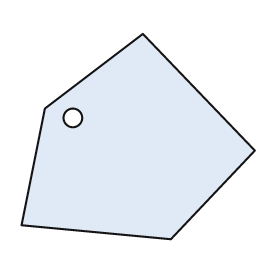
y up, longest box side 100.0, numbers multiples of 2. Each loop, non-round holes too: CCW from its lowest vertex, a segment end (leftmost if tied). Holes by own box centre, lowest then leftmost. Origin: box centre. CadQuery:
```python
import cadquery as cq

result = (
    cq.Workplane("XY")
    .moveTo(14.0, -44.0)
    .lineTo(50.0, -6.0)
    .lineTo(2.0, 44.0)
    .lineTo(-40.0, 12.0)
    .lineTo(-50.0, -38.0)
    .close()
    .moveTo(-28.0, 8.0)
    .circle(4.0)
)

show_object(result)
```